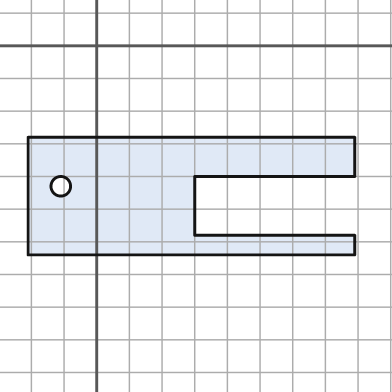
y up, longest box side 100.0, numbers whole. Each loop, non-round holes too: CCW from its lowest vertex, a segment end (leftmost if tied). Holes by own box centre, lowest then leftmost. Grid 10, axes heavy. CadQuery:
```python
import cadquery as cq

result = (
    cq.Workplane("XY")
    .moveTo(-21.0, -64.0)
    .lineTo(79.0, -64.0)
    .lineTo(79.0, -58.0)
    .lineTo(30.0, -58.0)
    .lineTo(30.0, -40.0)
    .lineTo(79.0, -40.0)
    .lineTo(79.0, -28.0)
    .lineTo(-21.0, -28.0)
    .close()
    .moveTo(-11.0, -43.0)
    .circle(3.0)
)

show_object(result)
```